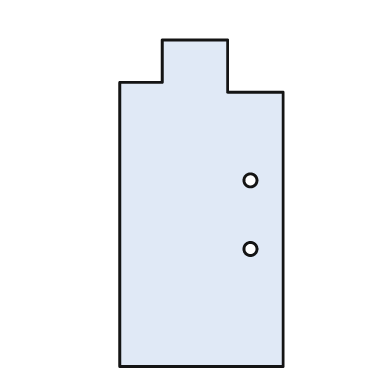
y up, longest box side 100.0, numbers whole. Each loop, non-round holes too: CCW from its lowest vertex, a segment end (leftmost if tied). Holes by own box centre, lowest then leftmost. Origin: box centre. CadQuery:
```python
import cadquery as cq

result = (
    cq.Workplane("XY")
    .moveTo(-25.0, -50.0)
    .lineTo(25.0, -50.0)
    .lineTo(25.0, 34.0)
    .lineTo(8.0, 34.0)
    .lineTo(8.0, 50.0)
    .lineTo(-12.0, 50.0)
    .lineTo(-12.0, 37.0)
    .lineTo(-25.0, 37.0)
    .close()
    .moveTo(15.0, -14.0)
    .circle(2.0)
    .moveTo(15.0, 7.0)
    .circle(2.0)
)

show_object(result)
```